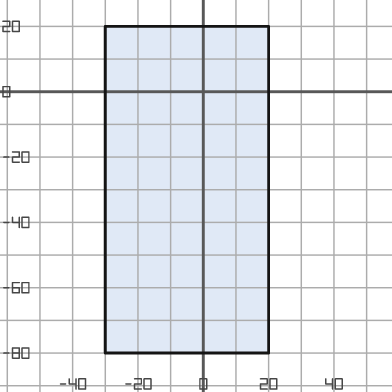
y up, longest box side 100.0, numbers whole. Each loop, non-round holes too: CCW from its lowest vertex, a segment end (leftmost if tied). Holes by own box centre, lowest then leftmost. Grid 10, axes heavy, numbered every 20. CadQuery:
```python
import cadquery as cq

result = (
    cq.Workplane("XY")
    .moveTo(-30.0, -80.0)
    .lineTo(20.0, -80.0)
    .lineTo(20.0, 20.0)
    .lineTo(-30.0, 20.0)
    .close()
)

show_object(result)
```